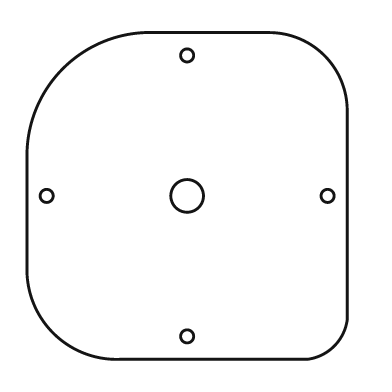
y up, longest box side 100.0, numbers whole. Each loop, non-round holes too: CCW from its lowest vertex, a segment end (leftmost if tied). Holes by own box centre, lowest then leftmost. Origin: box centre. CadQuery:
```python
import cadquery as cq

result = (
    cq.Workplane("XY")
    .moveTo(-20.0, -50.0)
    .lineTo(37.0, -50.0)
    .threePointArc((45.0, -46.0), (49.0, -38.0))
    .lineTo(49.0, 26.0)
    .threePointArc((42.0, 43.0), (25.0, 50.0))
    .lineTo(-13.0, 50.0)
    .threePointArc((-38.0, 39.0), (-49.0, 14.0))
    .lineTo(-49.0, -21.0)
    .threePointArc((-41.0, -42.0), (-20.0, -50.0))
    .close()
    .moveTo(0.0, -43.0)
    .circle(2.0)
    .moveTo(-43.0, 0.0)
    .circle(2.0)
    .moveTo(0.0, 0.0)
    .circle(5.0)
    .moveTo(43.0, 0.0)
    .circle(2.0)
    .moveTo(0.0, 43.0)
    .circle(2.0)
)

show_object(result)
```